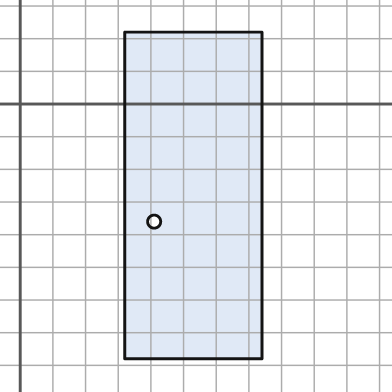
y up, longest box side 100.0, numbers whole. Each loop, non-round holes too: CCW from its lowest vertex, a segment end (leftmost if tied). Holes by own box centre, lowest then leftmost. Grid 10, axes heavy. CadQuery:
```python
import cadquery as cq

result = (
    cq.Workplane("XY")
    .moveTo(32.0, -78.0)
    .lineTo(74.0, -78.0)
    .lineTo(74.0, 22.0)
    .lineTo(32.0, 22.0)
    .close()
    .moveTo(41.0, -36.0)
    .circle(2.0)
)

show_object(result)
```